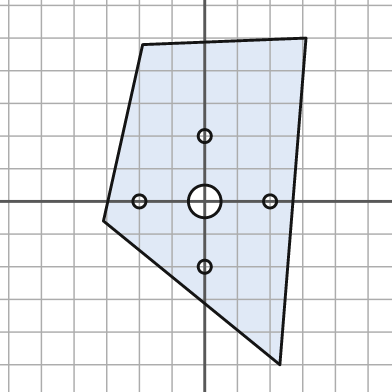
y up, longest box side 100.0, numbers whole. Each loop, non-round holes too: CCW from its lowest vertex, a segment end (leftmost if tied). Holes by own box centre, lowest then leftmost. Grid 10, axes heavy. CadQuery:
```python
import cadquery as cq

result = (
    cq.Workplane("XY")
    .moveTo(23.0, -50.0)
    .lineTo(31.0, 50.0)
    .lineTo(-19.0, 48.0)
    .lineTo(-31.0, -6.0)
    .close()
    .moveTo(0.0, -20.0)
    .circle(2.0)
    .moveTo(-20.0, 0.0)
    .circle(2.0)
    .moveTo(0.0, 0.0)
    .circle(5.0)
    .moveTo(20.0, 0.0)
    .circle(2.0)
    .moveTo(0.0, 20.0)
    .circle(2.0)
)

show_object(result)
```